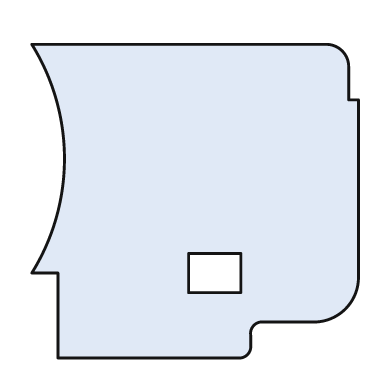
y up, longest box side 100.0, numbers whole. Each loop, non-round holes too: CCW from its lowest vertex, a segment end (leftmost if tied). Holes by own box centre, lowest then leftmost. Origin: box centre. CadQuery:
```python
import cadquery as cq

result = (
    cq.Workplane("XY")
    .moveTo(-42.0, -48.0)
    .lineTo(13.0, -48.0)
    .threePointArc((16.0, -47.0), (17.0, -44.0))
    .lineTo(17.0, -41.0)
    .threePointArc((18.0, -38.0), (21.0, -37.0))
    .lineTo(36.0, -37.0)
    .threePointArc((46.0, -33.0), (50.0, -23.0))
    .lineTo(50.0, 31.0)
    .lineTo(47.0, 31.0)
    .lineTo(47.0, 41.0)
    .threePointArc((45.0, 46.0), (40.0, 48.0))
    .lineTo(-50.0, 48.0)
    .threePointArc((-40.0, 13.0), (-50.0, -22.0))
    .lineTo(-42.0, -22.0)
    .close()
    .moveTo(-2.0, -28.0)
    .lineTo(14.0, -28.0)
    .lineTo(14.0, -16.0)
    .lineTo(-2.0, -16.0)
    .close()
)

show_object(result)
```